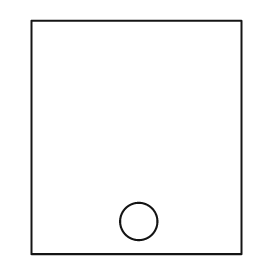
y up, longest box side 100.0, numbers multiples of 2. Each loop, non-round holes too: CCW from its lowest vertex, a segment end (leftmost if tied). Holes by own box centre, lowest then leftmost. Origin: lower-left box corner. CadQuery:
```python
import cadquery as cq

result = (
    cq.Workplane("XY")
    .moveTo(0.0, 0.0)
    .lineTo(90.0, 0.0)
    .lineTo(90.0, 100.0)
    .lineTo(0.0, 100.0)
    .close()
    .moveTo(46.0, 14.0)
    .circle(8.0)
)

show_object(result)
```